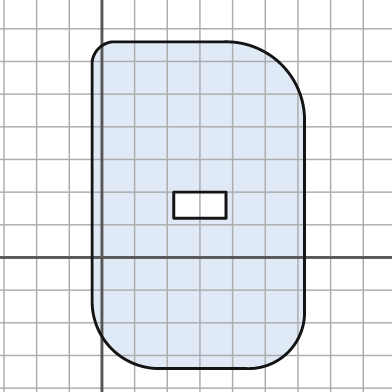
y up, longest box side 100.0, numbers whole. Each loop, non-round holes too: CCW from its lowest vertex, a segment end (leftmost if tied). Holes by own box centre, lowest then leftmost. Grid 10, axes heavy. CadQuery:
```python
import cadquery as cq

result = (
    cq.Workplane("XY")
    .moveTo(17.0, -34.0)
    .lineTo(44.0, -34.0)
    .threePointArc((57.0, -29.0), (62.0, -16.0))
    .lineTo(62.0, 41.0)
    .threePointArc((55.0, 59.0), (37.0, 66.0))
    .lineTo(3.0, 66.0)
    .threePointArc((-1.0, 64.0), (-3.0, 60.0))
    .lineTo(-3.0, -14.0)
    .threePointArc((3.0, -28.0), (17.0, -34.0))
    .close()
    .moveTo(22.0, 12.0)
    .lineTo(38.0, 12.0)
    .lineTo(38.0, 20.0)
    .lineTo(22.0, 20.0)
    .close()
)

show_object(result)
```